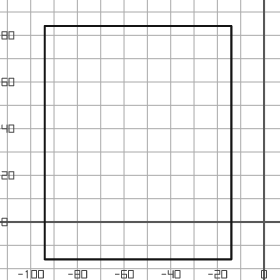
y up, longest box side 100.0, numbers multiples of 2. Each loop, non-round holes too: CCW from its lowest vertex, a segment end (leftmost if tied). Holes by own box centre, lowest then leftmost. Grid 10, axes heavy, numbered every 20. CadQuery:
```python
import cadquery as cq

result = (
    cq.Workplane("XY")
    .moveTo(-94.0, -16.0)
    .lineTo(-14.0, -16.0)
    .lineTo(-14.0, 84.0)
    .lineTo(-94.0, 84.0)
    .close()
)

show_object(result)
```